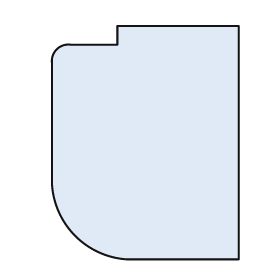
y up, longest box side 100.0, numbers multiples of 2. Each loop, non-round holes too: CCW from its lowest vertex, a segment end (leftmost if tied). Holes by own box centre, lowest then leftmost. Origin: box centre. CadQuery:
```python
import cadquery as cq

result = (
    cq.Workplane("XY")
    .moveTo(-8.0, -50.0)
    .lineTo(40.0, -50.0)
    .lineTo(40.0, 50.0)
    .lineTo(-12.0, 50.0)
    .lineTo(-12.0, 42.0)
    .lineTo(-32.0, 42.0)
    .threePointArc((-38.0, 40.0), (-40.0, 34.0))
    .lineTo(-40.0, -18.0)
    .threePointArc((-30.0, -40.0), (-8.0, -50.0))
    .close()
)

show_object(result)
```